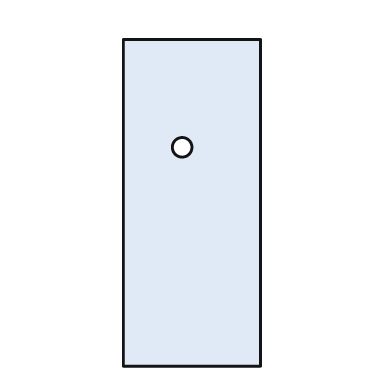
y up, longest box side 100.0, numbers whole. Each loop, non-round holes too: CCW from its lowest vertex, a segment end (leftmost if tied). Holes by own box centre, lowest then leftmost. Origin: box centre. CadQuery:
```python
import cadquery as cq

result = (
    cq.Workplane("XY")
    .moveTo(-21.0, -50.0)
    .lineTo(21.0, -50.0)
    .lineTo(21.0, 50.0)
    .lineTo(-21.0, 50.0)
    .close()
    .moveTo(-3.0, 17.0)
    .circle(3.0)
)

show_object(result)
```